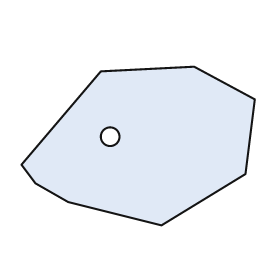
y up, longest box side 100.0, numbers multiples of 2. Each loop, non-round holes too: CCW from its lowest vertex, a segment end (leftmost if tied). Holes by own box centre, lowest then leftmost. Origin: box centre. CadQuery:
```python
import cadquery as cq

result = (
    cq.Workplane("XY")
    .moveTo(10.0, -34.0)
    .lineTo(46.0, -12.0)
    .lineTo(50.0, 20.0)
    .lineTo(24.0, 34.0)
    .lineTo(-16.0, 32.0)
    .lineTo(-50.0, -8.0)
    .lineTo(-44.0, -16.0)
    .lineTo(-30.0, -24.0)
    .close()
    .moveTo(-12.0, 4.0)
    .circle(4.0)
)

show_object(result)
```